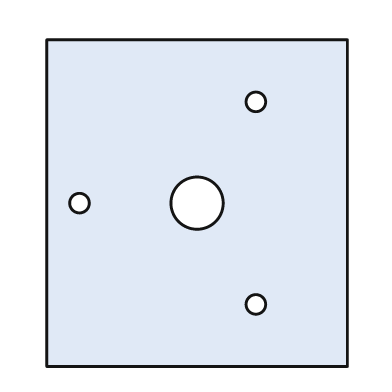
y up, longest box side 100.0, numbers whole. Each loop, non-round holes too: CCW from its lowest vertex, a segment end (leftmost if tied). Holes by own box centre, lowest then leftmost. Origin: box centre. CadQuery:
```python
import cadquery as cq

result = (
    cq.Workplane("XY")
    .moveTo(-46.0, -50.0)
    .lineTo(46.0, -50.0)
    .lineTo(46.0, 50.0)
    .lineTo(-46.0, 50.0)
    .close()
    .moveTo(18.0, -31.0)
    .circle(3.0)
    .moveTo(-36.0, 0.0)
    .circle(3.0)
    .moveTo(0.0, 0.0)
    .circle(8.0)
    .moveTo(18.0, 31.0)
    .circle(3.0)
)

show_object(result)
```